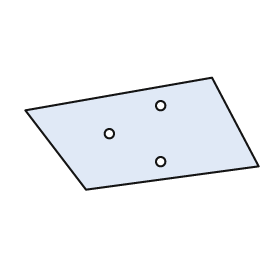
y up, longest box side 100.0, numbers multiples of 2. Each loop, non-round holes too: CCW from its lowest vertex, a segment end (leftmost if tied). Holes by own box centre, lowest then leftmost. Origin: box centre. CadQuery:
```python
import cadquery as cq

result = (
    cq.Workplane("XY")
    .moveTo(-24.0, -24.0)
    .lineTo(50.0, -14.0)
    .lineTo(30.0, 24.0)
    .lineTo(-50.0, 10.0)
    .close()
    .moveTo(8.0, -12.0)
    .circle(2.0)
    .moveTo(-14.0, 0.0)
    .circle(2.0)
    .moveTo(8.0, 12.0)
    .circle(2.0)
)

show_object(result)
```